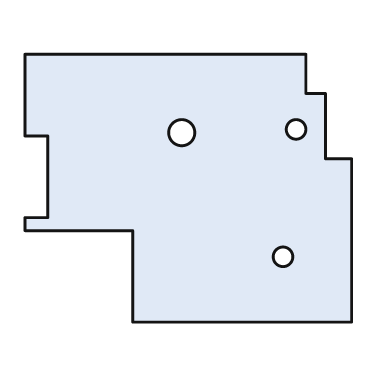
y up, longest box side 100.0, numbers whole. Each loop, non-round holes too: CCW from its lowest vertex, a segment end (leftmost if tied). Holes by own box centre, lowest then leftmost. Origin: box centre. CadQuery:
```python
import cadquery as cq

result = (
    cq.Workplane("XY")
    .moveTo(-17.0, -41.0)
    .lineTo(50.0, -41.0)
    .lineTo(50.0, 9.0)
    .lineTo(42.0, 9.0)
    .lineTo(42.0, 29.0)
    .lineTo(36.0, 29.0)
    .lineTo(36.0, 41.0)
    .lineTo(-50.0, 41.0)
    .lineTo(-50.0, 16.0)
    .lineTo(-43.0, 16.0)
    .lineTo(-43.0, -9.0)
    .lineTo(-50.0, -9.0)
    .lineTo(-50.0, -13.0)
    .lineTo(-17.0, -13.0)
    .close()
    .moveTo(29.0, -21.0)
    .circle(3.0)
    .moveTo(-2.0, 17.0)
    .circle(4.0)
    .moveTo(33.0, 18.0)
    .circle(3.0)
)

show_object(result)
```